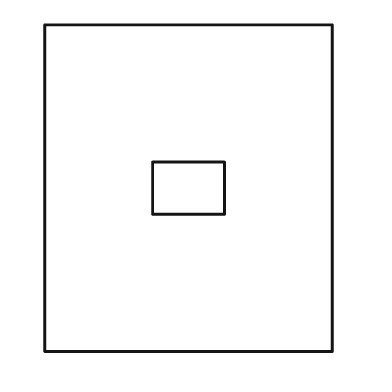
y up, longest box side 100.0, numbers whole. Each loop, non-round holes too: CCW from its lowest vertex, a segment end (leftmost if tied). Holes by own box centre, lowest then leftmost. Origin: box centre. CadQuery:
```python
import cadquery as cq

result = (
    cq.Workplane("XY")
    .moveTo(-44.0, -50.0)
    .lineTo(44.0, -50.0)
    .lineTo(44.0, 50.0)
    .lineTo(-44.0, 50.0)
    .close()
    .moveTo(-11.0, -8.0)
    .lineTo(11.0, -8.0)
    .lineTo(11.0, 8.0)
    .lineTo(-11.0, 8.0)
    .close()
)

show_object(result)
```